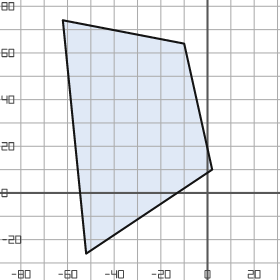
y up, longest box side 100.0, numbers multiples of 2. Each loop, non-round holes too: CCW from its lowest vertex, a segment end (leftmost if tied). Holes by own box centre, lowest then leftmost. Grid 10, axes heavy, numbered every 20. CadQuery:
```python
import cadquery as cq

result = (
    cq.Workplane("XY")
    .moveTo(-52.0, -26.0)
    .lineTo(2.0, 10.0)
    .lineTo(-10.0, 64.0)
    .lineTo(-62.0, 74.0)
    .close()
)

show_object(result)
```